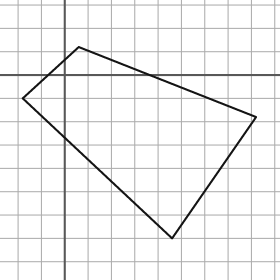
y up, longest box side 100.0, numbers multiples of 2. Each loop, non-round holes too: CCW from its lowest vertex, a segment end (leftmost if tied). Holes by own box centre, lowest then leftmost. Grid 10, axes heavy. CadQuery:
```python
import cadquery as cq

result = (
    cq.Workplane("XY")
    .moveTo(46.0, -70.0)
    .lineTo(82.0, -18.0)
    .lineTo(6.0, 12.0)
    .lineTo(-18.0, -10.0)
    .close()
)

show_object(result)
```